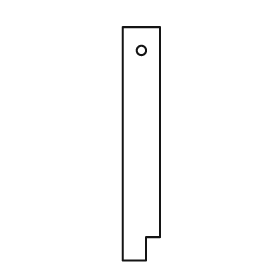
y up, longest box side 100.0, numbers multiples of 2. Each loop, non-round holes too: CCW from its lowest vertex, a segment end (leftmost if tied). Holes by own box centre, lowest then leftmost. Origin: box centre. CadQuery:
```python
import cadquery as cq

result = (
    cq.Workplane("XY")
    .moveTo(-8.0, -50.0)
    .lineTo(2.0, -50.0)
    .lineTo(2.0, -40.0)
    .lineTo(8.0, -40.0)
    .lineTo(8.0, 50.0)
    .lineTo(-8.0, 50.0)
    .close()
    .moveTo(0.0, 40.0)
    .circle(2.0)
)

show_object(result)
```